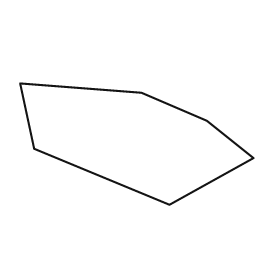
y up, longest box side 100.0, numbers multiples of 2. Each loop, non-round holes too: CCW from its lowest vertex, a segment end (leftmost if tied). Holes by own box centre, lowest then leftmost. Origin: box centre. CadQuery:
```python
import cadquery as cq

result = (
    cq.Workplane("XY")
    .moveTo(14.0, -26.0)
    .lineTo(50.0, -6.0)
    .lineTo(30.0, 10.0)
    .lineTo(2.0, 22.0)
    .lineTo(-50.0, 26.0)
    .lineTo(-44.0, -2.0)
    .close()
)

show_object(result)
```